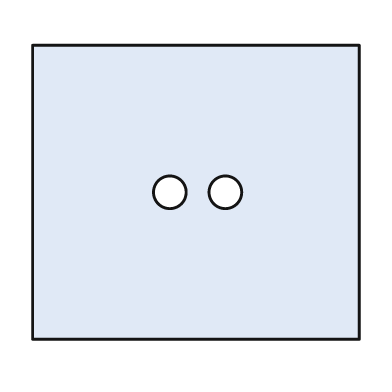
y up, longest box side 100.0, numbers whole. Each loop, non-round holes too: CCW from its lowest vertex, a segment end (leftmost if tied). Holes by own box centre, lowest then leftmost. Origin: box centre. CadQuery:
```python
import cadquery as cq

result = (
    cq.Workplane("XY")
    .moveTo(-50.0, -45.0)
    .lineTo(50.0, -45.0)
    .lineTo(50.0, 45.0)
    .lineTo(-50.0, 45.0)
    .close()
    .moveTo(-8.0, 0.0)
    .circle(5.0)
    .moveTo(9.0, 0.0)
    .circle(5.0)
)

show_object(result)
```